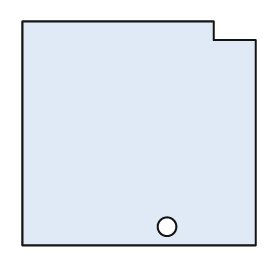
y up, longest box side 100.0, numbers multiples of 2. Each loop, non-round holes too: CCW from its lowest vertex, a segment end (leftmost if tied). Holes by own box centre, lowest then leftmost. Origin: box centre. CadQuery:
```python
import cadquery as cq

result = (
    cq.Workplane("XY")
    .moveTo(-50.0, -48.0)
    .lineTo(50.0, -48.0)
    .lineTo(50.0, 40.0)
    .lineTo(32.0, 40.0)
    .lineTo(32.0, 48.0)
    .lineTo(-50.0, 48.0)
    .close()
    .moveTo(12.0, -40.0)
    .circle(4.0)
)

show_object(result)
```